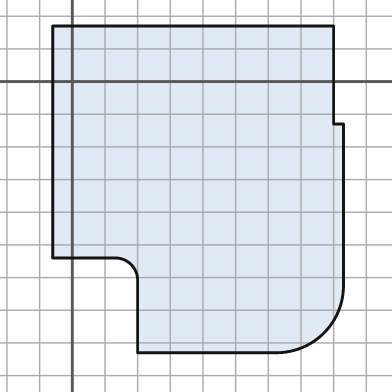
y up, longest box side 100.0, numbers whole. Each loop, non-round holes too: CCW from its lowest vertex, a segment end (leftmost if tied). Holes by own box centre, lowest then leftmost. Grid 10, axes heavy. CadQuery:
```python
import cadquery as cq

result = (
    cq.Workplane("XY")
    .moveTo(20.0, -83.0)
    .lineTo(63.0, -83.0)
    .threePointArc((77.0, -77.0), (83.0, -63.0))
    .lineTo(83.0, -13.0)
    .lineTo(80.0, -13.0)
    .lineTo(80.0, 17.0)
    .lineTo(-6.0, 17.0)
    .lineTo(-6.0, -54.0)
    .lineTo(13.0, -54.0)
    .threePointArc((18.0, -56.0), (20.0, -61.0))
    .close()
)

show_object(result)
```